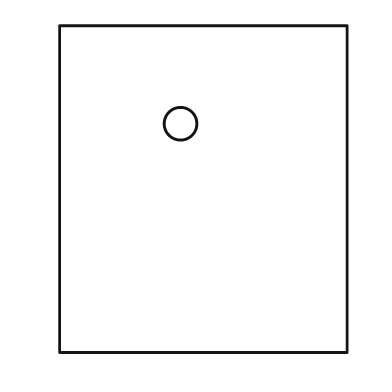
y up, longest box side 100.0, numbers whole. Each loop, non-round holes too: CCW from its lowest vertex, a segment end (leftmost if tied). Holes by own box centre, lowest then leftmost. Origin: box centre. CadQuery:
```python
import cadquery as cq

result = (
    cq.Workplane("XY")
    .moveTo(-44.0, -50.0)
    .lineTo(44.0, -50.0)
    .lineTo(44.0, 50.0)
    .lineTo(-44.0, 50.0)
    .close()
    .moveTo(-7.0, 20.0)
    .circle(5.0)
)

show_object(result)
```